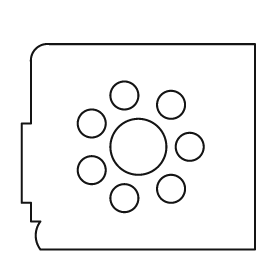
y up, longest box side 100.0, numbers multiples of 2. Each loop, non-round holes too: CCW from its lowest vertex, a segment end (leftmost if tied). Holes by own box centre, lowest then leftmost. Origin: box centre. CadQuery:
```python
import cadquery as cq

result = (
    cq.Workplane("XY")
    .moveTo(-42.0, -44.0)
    .lineTo(50.0, -44.0)
    .lineTo(50.0, 44.0)
    .lineTo(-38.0, 44.0)
    .threePointArc((-44.0, 42.0), (-46.0, 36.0))
    .lineTo(-46.0, 10.0)
    .lineTo(-50.0, 10.0)
    .lineTo(-50.0, -24.0)
    .lineTo(-46.0, -24.0)
    .lineTo(-46.0, -32.0)
    .lineTo(-42.0, -32.0)
    .threePointArc((-44.0, -38.0), (-42.0, -44.0))
    .close()
    .moveTo(-6.0, -22.0)
    .circle(6.0)
    .moveTo(14.0, -18.0)
    .circle(6.0)
    .moveTo(-20.0, -10.0)
    .circle(6.0)
    .moveTo(0.0, 0.0)
    .circle(12.0)
    .moveTo(22.0, 0.0)
    .circle(6.0)
    .moveTo(-20.0, 10.0)
    .circle(6.0)
    .moveTo(14.0, 18.0)
    .circle(6.0)
    .moveTo(-6.0, 22.0)
    .circle(6.0)
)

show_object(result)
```